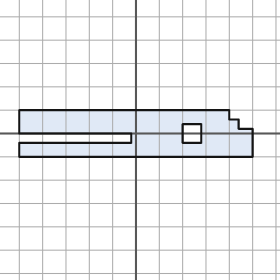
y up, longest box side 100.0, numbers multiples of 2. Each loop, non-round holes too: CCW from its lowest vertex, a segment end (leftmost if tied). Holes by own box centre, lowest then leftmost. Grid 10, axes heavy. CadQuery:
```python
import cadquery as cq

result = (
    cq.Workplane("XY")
    .moveTo(-50.0, -10.0)
    .lineTo(50.0, -10.0)
    .lineTo(50.0, 2.0)
    .lineTo(44.0, 2.0)
    .lineTo(44.0, 6.0)
    .lineTo(40.0, 6.0)
    .lineTo(40.0, 10.0)
    .lineTo(-50.0, 10.0)
    .lineTo(-50.0, 0.0)
    .lineTo(-2.0, 0.0)
    .lineTo(-2.0, -4.0)
    .lineTo(-50.0, -4.0)
    .close()
    .moveTo(20.0, -4.0)
    .lineTo(28.0, -4.0)
    .lineTo(28.0, 4.0)
    .lineTo(20.0, 4.0)
    .close()
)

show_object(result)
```